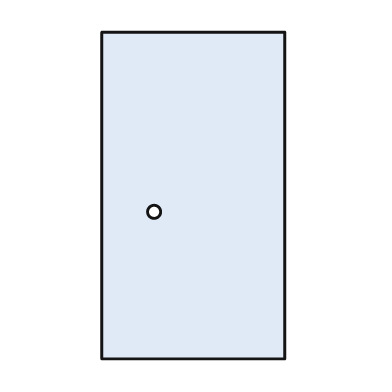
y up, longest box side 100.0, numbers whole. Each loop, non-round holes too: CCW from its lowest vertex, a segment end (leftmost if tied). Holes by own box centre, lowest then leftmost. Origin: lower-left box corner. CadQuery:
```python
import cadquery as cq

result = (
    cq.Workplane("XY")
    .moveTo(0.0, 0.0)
    .lineTo(56.0, 0.0)
    .lineTo(56.0, 100.0)
    .lineTo(0.0, 100.0)
    .close()
    .moveTo(16.0, 45.0)
    .circle(2.0)
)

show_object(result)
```